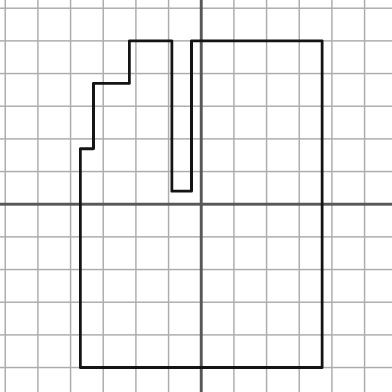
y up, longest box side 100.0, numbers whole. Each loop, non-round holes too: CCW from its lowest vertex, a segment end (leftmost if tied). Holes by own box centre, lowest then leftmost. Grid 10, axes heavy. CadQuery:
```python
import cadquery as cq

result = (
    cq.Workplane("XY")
    .moveTo(-37.0, -50.0)
    .lineTo(37.0, -50.0)
    .lineTo(37.0, 50.0)
    .lineTo(-3.0, 50.0)
    .lineTo(-3.0, 4.0)
    .lineTo(-9.0, 4.0)
    .lineTo(-9.0, 50.0)
    .lineTo(-22.0, 50.0)
    .lineTo(-22.0, 37.0)
    .lineTo(-33.0, 37.0)
    .lineTo(-33.0, 17.0)
    .lineTo(-37.0, 17.0)
    .close()
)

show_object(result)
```